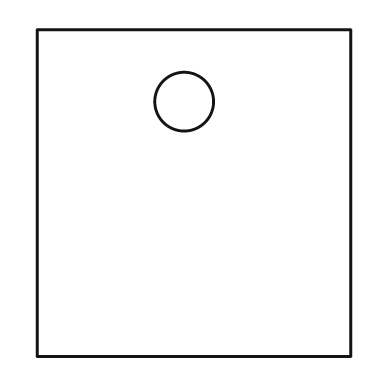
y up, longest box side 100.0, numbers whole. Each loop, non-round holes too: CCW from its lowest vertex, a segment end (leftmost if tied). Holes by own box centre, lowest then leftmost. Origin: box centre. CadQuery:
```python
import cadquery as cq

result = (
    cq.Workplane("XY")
    .moveTo(-48.0, -50.0)
    .lineTo(48.0, -50.0)
    .lineTo(48.0, 50.0)
    .lineTo(-48.0, 50.0)
    .close()
    .moveTo(-3.0, 28.0)
    .circle(9.0)
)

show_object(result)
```